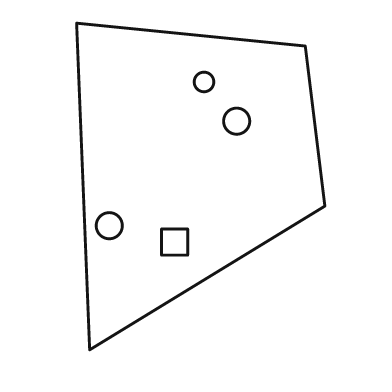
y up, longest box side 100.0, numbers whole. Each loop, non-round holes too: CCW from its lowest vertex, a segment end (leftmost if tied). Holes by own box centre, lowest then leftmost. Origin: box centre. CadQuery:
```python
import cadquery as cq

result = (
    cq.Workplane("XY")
    .moveTo(-34.0, -50.0)
    .lineTo(38.0, -6.0)
    .lineTo(32.0, 43.0)
    .lineTo(-38.0, 50.0)
    .close()
    .moveTo(-12.0, -21.0)
    .lineTo(-4.0, -21.0)
    .lineTo(-4.0, -13.0)
    .lineTo(-12.0, -13.0)
    .close()
    .moveTo(-28.0, -12.0)
    .circle(4.0)
    .moveTo(11.0, 20.0)
    .circle(4.0)
    .moveTo(1.0, 32.0)
    .circle(3.0)
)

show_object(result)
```